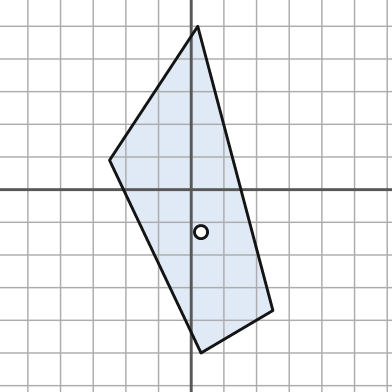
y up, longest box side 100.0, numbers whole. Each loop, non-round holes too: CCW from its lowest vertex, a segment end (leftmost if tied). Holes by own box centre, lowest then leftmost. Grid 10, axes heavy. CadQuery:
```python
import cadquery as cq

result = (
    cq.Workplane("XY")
    .moveTo(3.0, -50.0)
    .lineTo(25.0, -37.0)
    .lineTo(2.0, 50.0)
    .lineTo(-25.0, 9.0)
    .close()
    .moveTo(3.0, -13.0)
    .circle(2.0)
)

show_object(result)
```